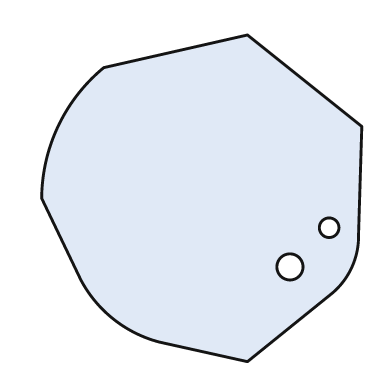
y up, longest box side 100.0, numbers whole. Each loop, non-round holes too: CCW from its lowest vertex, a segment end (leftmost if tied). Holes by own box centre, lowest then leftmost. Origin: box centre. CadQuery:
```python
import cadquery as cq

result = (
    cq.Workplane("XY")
    .moveTo(14.0, -50.0)
    .lineTo(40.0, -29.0)
    .threePointArc((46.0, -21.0), (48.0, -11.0))
    .lineTo(49.0, 22.0)
    .lineTo(14.0, 50.0)
    .lineTo(-30.0, 40.0)
    .threePointArc((-44.0, 22.0), (-49.0, 0.0))
    .lineTo(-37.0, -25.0)
    .threePointArc((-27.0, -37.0), (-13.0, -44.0))
    .close()
    .moveTo(27.0, -21.0)
    .circle(4.0)
    .moveTo(39.0, -9.0)
    .circle(3.0)
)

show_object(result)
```